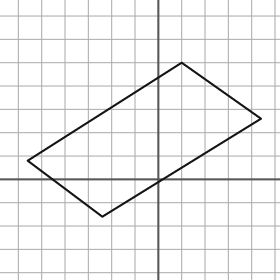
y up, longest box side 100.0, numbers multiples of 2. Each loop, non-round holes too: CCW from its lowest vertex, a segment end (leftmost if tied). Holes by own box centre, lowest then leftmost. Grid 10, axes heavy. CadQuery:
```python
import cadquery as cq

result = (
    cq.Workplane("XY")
    .moveTo(-24.0, -16.0)
    .lineTo(44.0, 26.0)
    .lineTo(10.0, 50.0)
    .lineTo(-56.0, 8.0)
    .close()
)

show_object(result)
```